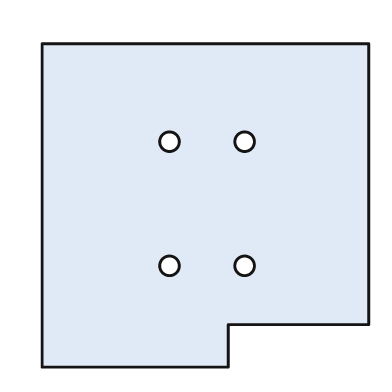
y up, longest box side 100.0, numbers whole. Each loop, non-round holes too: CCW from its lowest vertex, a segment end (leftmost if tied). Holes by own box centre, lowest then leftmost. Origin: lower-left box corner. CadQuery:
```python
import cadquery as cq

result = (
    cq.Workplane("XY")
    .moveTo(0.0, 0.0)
    .lineTo(57.0, 0.0)
    .lineTo(57.0, 13.0)
    .lineTo(100.0, 13.0)
    .lineTo(100.0, 99.0)
    .lineTo(0.0, 99.0)
    .close()
    .moveTo(39.0, 31.0)
    .circle(3.0)
    .moveTo(62.0, 31.0)
    .circle(3.0)
    .moveTo(39.0, 69.0)
    .circle(3.0)
    .moveTo(62.0, 69.0)
    .circle(3.0)
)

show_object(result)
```